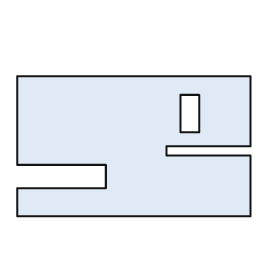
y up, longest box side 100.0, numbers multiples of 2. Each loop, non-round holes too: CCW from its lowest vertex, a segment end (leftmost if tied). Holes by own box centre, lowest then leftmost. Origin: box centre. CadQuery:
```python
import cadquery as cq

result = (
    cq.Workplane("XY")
    .moveTo(-50.0, -30.0)
    .lineTo(50.0, -30.0)
    .lineTo(50.0, -4.0)
    .lineTo(14.0, -4.0)
    .lineTo(14.0, 0.0)
    .lineTo(50.0, 0.0)
    .lineTo(50.0, 30.0)
    .lineTo(-50.0, 30.0)
    .lineTo(-50.0, -8.0)
    .lineTo(-12.0, -8.0)
    .lineTo(-12.0, -18.0)
    .lineTo(-50.0, -18.0)
    .close()
    .moveTo(20.0, 6.0)
    .lineTo(28.0, 6.0)
    .lineTo(28.0, 22.0)
    .lineTo(20.0, 22.0)
    .close()
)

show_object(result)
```